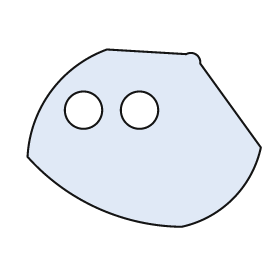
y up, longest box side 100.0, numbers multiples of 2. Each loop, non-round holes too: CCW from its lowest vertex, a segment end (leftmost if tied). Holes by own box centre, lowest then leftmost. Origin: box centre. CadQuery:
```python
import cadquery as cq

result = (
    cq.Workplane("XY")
    .moveTo(16.0, -38.0)
    .threePointArc((38.0, -26.0), (50.0, -4.0))
    .lineTo(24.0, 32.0)
    .threePointArc((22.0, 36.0), (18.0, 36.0))
    .lineTo(-16.0, 38.0)
    .threePointArc((-40.0, 20.0), (-50.0, -8.0))
    .threePointArc((-20.0, -30.0), (16.0, -38.0))
    .close()
    .moveTo(-26.0, 12.0)
    .circle(8.0)
    .moveTo(-2.0, 12.0)
    .circle(8.0)
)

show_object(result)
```